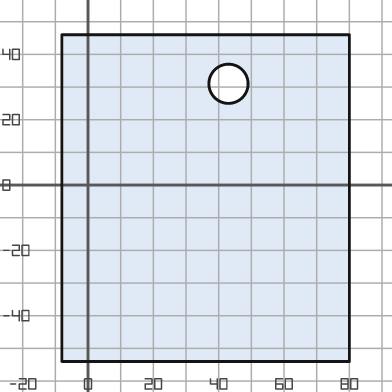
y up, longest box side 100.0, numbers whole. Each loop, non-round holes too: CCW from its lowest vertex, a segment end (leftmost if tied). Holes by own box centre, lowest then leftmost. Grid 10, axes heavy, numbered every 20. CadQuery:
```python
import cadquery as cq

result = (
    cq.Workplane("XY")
    .moveTo(-8.0, -54.0)
    .lineTo(80.0, -54.0)
    .lineTo(80.0, 46.0)
    .lineTo(-8.0, 46.0)
    .close()
    .moveTo(43.0, 31.0)
    .circle(6.0)
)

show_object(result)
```